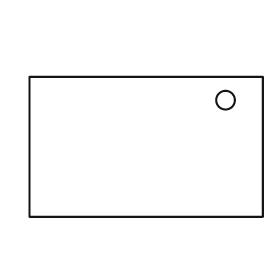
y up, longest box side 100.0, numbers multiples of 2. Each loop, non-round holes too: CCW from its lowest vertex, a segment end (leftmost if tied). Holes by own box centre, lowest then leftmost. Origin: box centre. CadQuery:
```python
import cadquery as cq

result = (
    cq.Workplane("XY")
    .moveTo(-50.0, -30.0)
    .lineTo(50.0, -30.0)
    .lineTo(50.0, 30.0)
    .lineTo(-50.0, 30.0)
    .close()
    .moveTo(34.0, 20.0)
    .circle(4.0)
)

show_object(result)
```